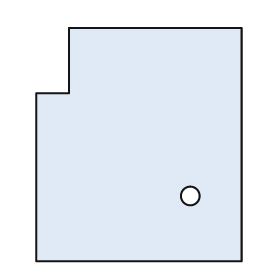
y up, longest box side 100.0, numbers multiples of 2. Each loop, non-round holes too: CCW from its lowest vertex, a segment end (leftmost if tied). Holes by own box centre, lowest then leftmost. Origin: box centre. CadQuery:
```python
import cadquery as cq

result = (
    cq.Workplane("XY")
    .moveTo(-44.0, -50.0)
    .lineTo(44.0, -50.0)
    .lineTo(44.0, 50.0)
    .lineTo(-30.0, 50.0)
    .lineTo(-30.0, 22.0)
    .lineTo(-44.0, 22.0)
    .close()
    .moveTo(22.0, -22.0)
    .circle(4.0)
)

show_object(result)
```